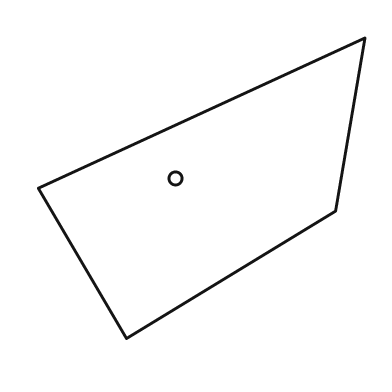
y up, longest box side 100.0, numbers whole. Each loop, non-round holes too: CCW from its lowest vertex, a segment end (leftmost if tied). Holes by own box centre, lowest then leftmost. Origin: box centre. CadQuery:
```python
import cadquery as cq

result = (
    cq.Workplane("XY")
    .moveTo(-23.0, -46.0)
    .lineTo(41.0, -7.0)
    .lineTo(50.0, 46.0)
    .lineTo(-50.0, 0.0)
    .close()
    .moveTo(-8.0, 3.0)
    .circle(2.0)
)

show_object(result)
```